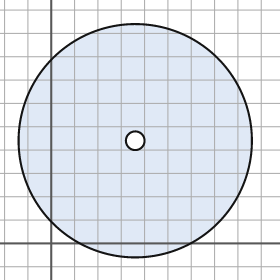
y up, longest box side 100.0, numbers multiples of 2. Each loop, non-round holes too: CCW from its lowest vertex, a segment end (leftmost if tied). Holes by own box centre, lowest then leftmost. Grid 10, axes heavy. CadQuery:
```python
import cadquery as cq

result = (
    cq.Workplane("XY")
    .moveTo(36.0, 44.0)
    .circle(50.0)
    .moveTo(36.0, 44.0)
    .circle(4.0)
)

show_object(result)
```